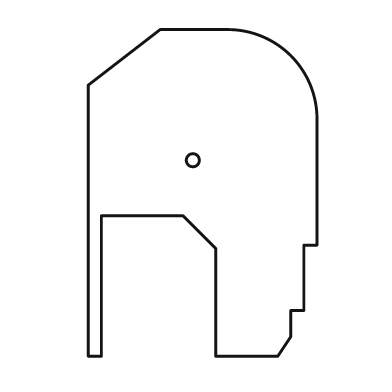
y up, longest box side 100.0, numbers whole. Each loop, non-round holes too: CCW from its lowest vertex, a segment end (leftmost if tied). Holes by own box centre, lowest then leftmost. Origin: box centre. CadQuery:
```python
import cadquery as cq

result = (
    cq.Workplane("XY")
    .moveTo(-35.0, -50.0)
    .lineTo(-31.0, -50.0)
    .lineTo(-31.0, -7.0)
    .lineTo(-6.0, -7.0)
    .lineTo(4.0, -17.0)
    .lineTo(4.0, -50.0)
    .lineTo(23.0, -50.0)
    .lineTo(27.0, -44.0)
    .lineTo(27.0, -36.0)
    .lineTo(31.0, -36.0)
    .lineTo(31.0, -16.0)
    .lineTo(35.0, -16.0)
    .lineTo(35.0, 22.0)
    .threePointArc((27.0, 42.0), (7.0, 50.0))
    .lineTo(-13.0, 50.0)
    .lineTo(-35.0, 33.0)
    .close()
    .moveTo(-3.0, 10.0)
    .circle(2.0)
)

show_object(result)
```